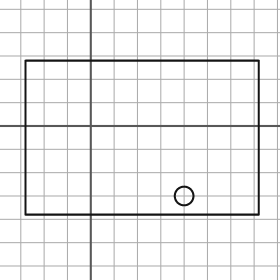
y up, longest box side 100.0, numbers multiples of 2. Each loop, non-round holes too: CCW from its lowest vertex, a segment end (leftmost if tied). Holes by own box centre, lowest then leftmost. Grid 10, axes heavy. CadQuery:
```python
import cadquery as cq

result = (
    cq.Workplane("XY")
    .moveTo(-28.0, -38.0)
    .lineTo(72.0, -38.0)
    .lineTo(72.0, 28.0)
    .lineTo(-28.0, 28.0)
    .close()
    .moveTo(40.0, -30.0)
    .circle(4.0)
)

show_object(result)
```